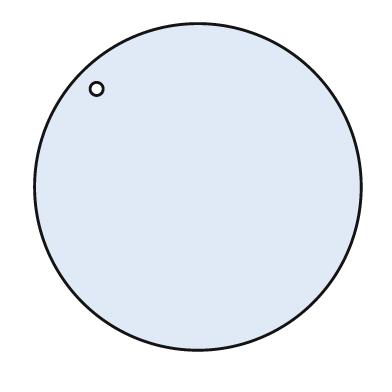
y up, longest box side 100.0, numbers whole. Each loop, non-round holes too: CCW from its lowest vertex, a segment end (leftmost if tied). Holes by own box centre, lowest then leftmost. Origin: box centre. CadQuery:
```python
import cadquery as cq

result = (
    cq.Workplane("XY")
    .moveTo(0.0, 0.0)
    .circle(50.0)
    .moveTo(-31.0, 30.0)
    .circle(2.0)
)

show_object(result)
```